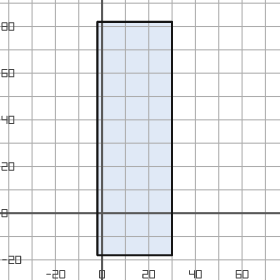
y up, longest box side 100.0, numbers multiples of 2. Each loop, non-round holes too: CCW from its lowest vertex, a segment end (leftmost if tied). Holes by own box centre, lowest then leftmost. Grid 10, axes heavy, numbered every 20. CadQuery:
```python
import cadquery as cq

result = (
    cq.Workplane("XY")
    .moveTo(-2.0, -18.0)
    .lineTo(30.0, -18.0)
    .lineTo(30.0, 82.0)
    .lineTo(-2.0, 82.0)
    .close()
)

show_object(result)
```